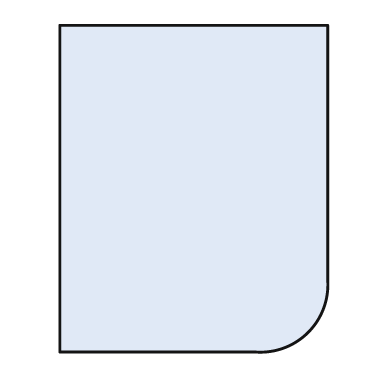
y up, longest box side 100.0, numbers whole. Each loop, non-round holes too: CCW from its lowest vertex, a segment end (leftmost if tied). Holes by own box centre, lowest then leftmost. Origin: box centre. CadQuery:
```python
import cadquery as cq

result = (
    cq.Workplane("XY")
    .moveTo(-41.0, -50.0)
    .lineTo(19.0, -50.0)
    .threePointArc((35.0, -44.0), (41.0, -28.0))
    .lineTo(41.0, 50.0)
    .lineTo(-41.0, 50.0)
    .close()
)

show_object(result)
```